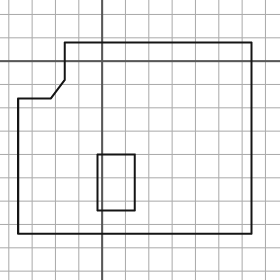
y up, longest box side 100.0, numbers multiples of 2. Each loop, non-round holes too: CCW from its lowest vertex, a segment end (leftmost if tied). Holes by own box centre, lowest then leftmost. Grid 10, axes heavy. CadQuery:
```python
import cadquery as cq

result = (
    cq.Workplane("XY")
    .moveTo(-36.0, -74.0)
    .lineTo(64.0, -74.0)
    .lineTo(64.0, 8.0)
    .lineTo(-16.0, 8.0)
    .lineTo(-16.0, -8.0)
    .lineTo(-22.0, -16.0)
    .lineTo(-36.0, -16.0)
    .close()
    .moveTo(-2.0, -64.0)
    .lineTo(14.0, -64.0)
    .lineTo(14.0, -40.0)
    .lineTo(-2.0, -40.0)
    .close()
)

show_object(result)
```